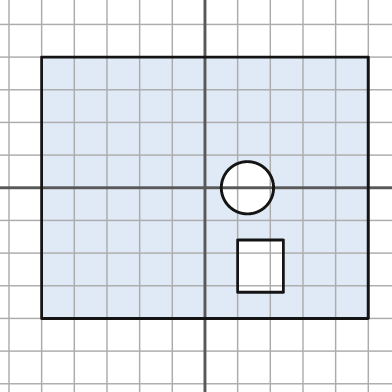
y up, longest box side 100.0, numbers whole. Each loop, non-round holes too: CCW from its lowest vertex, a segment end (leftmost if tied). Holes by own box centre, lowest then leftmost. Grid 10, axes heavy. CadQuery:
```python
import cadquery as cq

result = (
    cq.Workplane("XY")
    .moveTo(-50.0, -40.0)
    .lineTo(50.0, -40.0)
    .lineTo(50.0, 40.0)
    .lineTo(-50.0, 40.0)
    .close()
    .moveTo(10.0, -32.0)
    .lineTo(24.0, -32.0)
    .lineTo(24.0, -16.0)
    .lineTo(10.0, -16.0)
    .close()
    .moveTo(13.0, 0.0)
    .circle(8.0)
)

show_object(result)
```